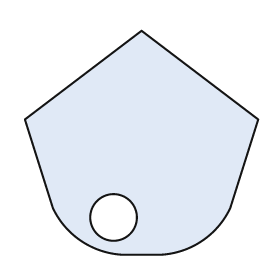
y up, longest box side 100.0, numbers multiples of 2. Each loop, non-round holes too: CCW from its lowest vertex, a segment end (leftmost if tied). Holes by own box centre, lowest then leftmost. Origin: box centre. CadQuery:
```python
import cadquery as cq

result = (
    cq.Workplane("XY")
    .moveTo(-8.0, -48.0)
    .lineTo(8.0, -48.0)
    .threePointArc((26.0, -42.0), (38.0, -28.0))
    .lineTo(50.0, 10.0)
    .lineTo(0.0, 48.0)
    .lineTo(-50.0, 10.0)
    .lineTo(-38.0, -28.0)
    .threePointArc((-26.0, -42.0), (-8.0, -48.0))
    .close()
    .moveTo(-12.0, -32.0)
    .circle(10.0)
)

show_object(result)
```